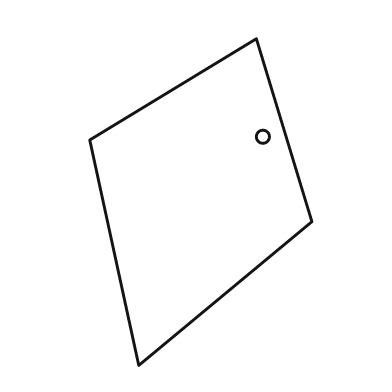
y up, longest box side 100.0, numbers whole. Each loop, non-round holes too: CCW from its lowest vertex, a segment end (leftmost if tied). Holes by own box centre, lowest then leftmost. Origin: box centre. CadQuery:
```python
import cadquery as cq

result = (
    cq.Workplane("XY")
    .moveTo(-19.0, -50.0)
    .lineTo(34.0, -6.0)
    .lineTo(17.0, 50.0)
    .lineTo(-34.0, 19.0)
    .close()
    .moveTo(19.0, 20.0)
    .circle(2.0)
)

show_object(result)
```